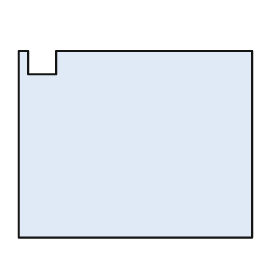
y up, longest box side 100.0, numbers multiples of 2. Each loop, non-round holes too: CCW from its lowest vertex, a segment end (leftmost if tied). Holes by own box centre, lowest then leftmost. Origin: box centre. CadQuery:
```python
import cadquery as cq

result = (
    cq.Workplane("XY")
    .moveTo(-50.0, -40.0)
    .lineTo(50.0, -40.0)
    .lineTo(50.0, 40.0)
    .lineTo(-34.0, 40.0)
    .lineTo(-34.0, 30.0)
    .lineTo(-46.0, 30.0)
    .lineTo(-46.0, 40.0)
    .lineTo(-50.0, 40.0)
    .close()
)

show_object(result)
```